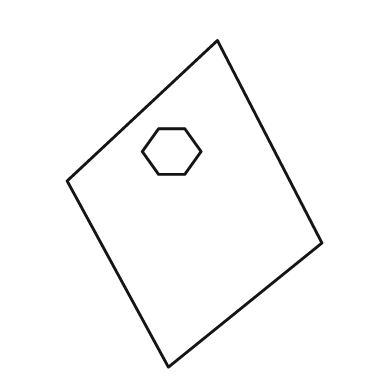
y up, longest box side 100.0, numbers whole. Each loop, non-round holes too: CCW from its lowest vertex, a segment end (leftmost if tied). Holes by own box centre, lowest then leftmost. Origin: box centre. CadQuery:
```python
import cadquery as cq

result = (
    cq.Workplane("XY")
    .moveTo(-8.0, -50.0)
    .lineTo(39.0, -12.0)
    .lineTo(7.0, 50.0)
    .lineTo(-39.0, 7.0)
    .close()
    .moveTo(-11.0, 9.0)
    .lineTo(-3.0, 9.0)
    .lineTo(2.0, 16.0)
    .lineTo(-3.0, 23.0)
    .lineTo(-11.0, 23.0)
    .lineTo(-16.0, 16.0)
    .close()
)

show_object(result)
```